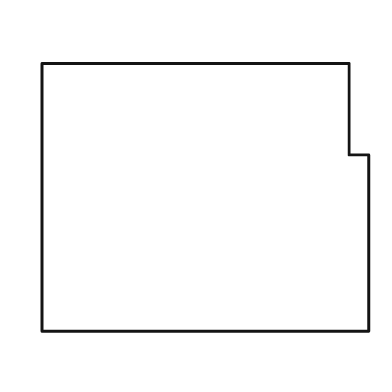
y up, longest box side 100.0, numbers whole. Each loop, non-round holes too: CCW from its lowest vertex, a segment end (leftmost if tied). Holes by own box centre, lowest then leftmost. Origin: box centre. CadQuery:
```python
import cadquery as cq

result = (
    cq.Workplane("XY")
    .moveTo(-50.0, -41.0)
    .lineTo(50.0, -41.0)
    .lineTo(50.0, 13.0)
    .lineTo(44.0, 13.0)
    .lineTo(44.0, 41.0)
    .lineTo(-50.0, 41.0)
    .close()
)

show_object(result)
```